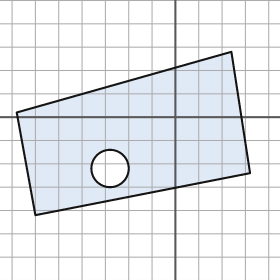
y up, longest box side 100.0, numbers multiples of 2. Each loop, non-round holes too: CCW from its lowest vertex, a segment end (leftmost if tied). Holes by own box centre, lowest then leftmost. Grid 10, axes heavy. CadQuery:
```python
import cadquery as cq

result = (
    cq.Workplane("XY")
    .moveTo(-60.0, -42.0)
    .lineTo(32.0, -24.0)
    .lineTo(24.0, 28.0)
    .lineTo(-68.0, 2.0)
    .close()
    .moveTo(-28.0, -22.0)
    .circle(8.0)
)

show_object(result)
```